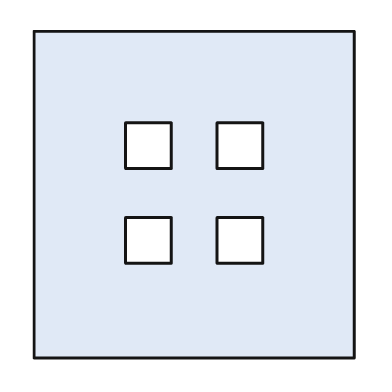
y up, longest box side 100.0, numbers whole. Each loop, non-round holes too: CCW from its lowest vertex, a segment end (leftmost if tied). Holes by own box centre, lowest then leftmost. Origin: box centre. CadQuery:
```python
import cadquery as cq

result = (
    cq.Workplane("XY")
    .moveTo(-49.0, -50.0)
    .lineTo(49.0, -50.0)
    .lineTo(49.0, 50.0)
    .lineTo(-49.0, 50.0)
    .close()
    .moveTo(-21.0, -21.0)
    .lineTo(-7.0, -21.0)
    .lineTo(-7.0, -7.0)
    .lineTo(-21.0, -7.0)
    .close()
    .moveTo(7.0, -21.0)
    .lineTo(21.0, -21.0)
    .lineTo(21.0, -7.0)
    .lineTo(7.0, -7.0)
    .close()
    .moveTo(-21.0, 8.0)
    .lineTo(-7.0, 8.0)
    .lineTo(-7.0, 22.0)
    .lineTo(-21.0, 22.0)
    .close()
    .moveTo(7.0, 8.0)
    .lineTo(21.0, 8.0)
    .lineTo(21.0, 22.0)
    .lineTo(7.0, 22.0)
    .close()
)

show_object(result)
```